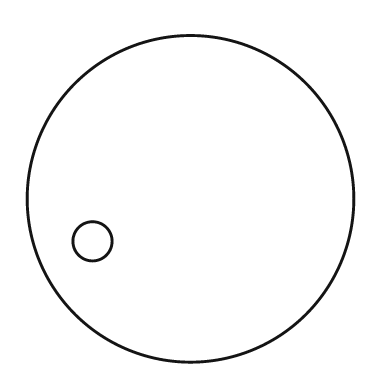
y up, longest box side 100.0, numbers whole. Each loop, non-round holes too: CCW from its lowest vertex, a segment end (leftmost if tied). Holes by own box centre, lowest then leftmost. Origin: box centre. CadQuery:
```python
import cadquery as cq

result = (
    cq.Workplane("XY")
    .moveTo(0.0, 0.0)
    .circle(50.0)
    .moveTo(-30.0, -13.0)
    .circle(6.0)
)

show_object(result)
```